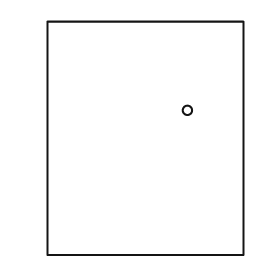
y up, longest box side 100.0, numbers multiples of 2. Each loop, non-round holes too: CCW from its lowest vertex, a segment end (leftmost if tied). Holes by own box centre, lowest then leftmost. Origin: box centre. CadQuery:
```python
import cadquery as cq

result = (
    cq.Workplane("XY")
    .moveTo(-42.0, -50.0)
    .lineTo(42.0, -50.0)
    .lineTo(42.0, 50.0)
    .lineTo(-42.0, 50.0)
    .close()
    .moveTo(18.0, 12.0)
    .circle(2.0)
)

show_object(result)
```